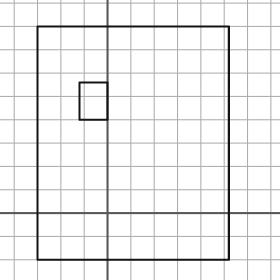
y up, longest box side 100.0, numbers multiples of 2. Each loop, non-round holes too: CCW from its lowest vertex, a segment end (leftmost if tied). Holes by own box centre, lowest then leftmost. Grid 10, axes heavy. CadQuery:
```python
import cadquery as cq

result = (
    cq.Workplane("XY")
    .moveTo(-30.0, -20.0)
    .lineTo(52.0, -20.0)
    .lineTo(52.0, 80.0)
    .lineTo(-30.0, 80.0)
    .close()
    .moveTo(-12.0, 40.0)
    .lineTo(0.0, 40.0)
    .lineTo(0.0, 56.0)
    .lineTo(-12.0, 56.0)
    .close()
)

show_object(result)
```